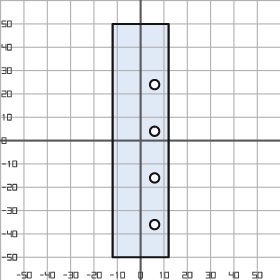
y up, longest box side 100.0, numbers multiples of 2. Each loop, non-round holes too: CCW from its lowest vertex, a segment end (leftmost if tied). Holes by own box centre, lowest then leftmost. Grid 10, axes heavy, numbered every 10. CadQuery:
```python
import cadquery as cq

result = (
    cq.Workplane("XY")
    .moveTo(-12.0, -50.0)
    .lineTo(12.0, -50.0)
    .lineTo(12.0, 50.0)
    .lineTo(-12.0, 50.0)
    .close()
    .moveTo(6.0, -36.0)
    .circle(2.0)
    .moveTo(6.0, -16.0)
    .circle(2.0)
    .moveTo(6.0, 4.0)
    .circle(2.0)
    .moveTo(6.0, 24.0)
    .circle(2.0)
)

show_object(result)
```